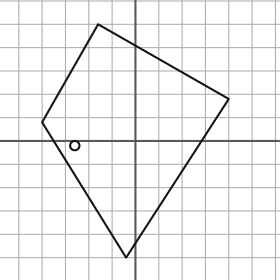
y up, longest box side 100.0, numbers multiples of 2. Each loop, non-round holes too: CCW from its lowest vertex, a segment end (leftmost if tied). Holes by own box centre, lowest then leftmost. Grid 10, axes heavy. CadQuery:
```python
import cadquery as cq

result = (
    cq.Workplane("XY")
    .moveTo(-4.0, -50.0)
    .lineTo(40.0, 18.0)
    .lineTo(-16.0, 50.0)
    .lineTo(-40.0, 8.0)
    .close()
    .moveTo(-26.0, -2.0)
    .circle(2.0)
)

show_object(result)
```